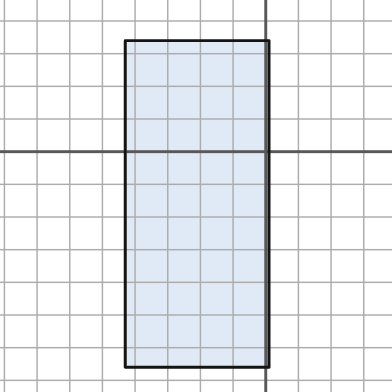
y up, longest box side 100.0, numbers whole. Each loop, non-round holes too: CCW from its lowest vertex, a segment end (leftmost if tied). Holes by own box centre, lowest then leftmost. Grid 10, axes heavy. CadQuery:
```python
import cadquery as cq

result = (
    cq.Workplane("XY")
    .moveTo(-43.0, -66.0)
    .lineTo(1.0, -66.0)
    .lineTo(1.0, 34.0)
    .lineTo(-43.0, 34.0)
    .close()
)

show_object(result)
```